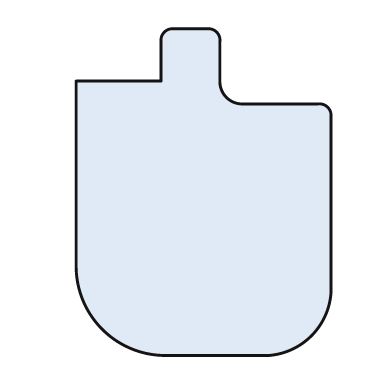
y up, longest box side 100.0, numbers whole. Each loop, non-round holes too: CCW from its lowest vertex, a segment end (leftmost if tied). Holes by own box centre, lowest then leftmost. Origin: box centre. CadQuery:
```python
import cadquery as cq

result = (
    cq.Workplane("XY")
    .moveTo(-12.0, -50.0)
    .lineTo(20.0, -50.0)
    .threePointArc((33.0, -44.0), (39.0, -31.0))
    .lineTo(39.0, 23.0)
    .threePointArc((38.0, 26.0), (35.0, 27.0))
    .lineTo(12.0, 27.0)
    .threePointArc((7.0, 29.0), (5.0, 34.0))
    .lineTo(5.0, 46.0)
    .threePointArc((4.0, 49.0), (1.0, 50.0))
    .lineTo(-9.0, 50.0)
    .threePointArc((-12.0, 49.0), (-13.0, 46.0))
    .lineTo(-13.0, 34.0)
    .lineTo(-39.0, 34.0)
    .lineTo(-39.0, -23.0)
    .threePointArc((-31.0, -42.0), (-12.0, -50.0))
    .close()
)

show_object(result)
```